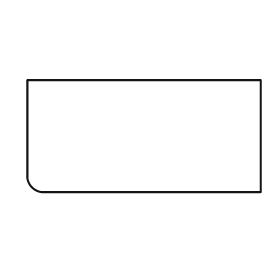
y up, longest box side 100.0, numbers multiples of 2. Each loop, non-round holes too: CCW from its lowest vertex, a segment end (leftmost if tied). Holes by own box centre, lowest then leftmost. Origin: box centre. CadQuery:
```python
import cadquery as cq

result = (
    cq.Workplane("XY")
    .moveTo(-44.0, -24.0)
    .lineTo(50.0, -24.0)
    .lineTo(50.0, 24.0)
    .lineTo(-50.0, 24.0)
    .lineTo(-50.0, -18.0)
    .threePointArc((-48.0, -22.0), (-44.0, -24.0))
    .close()
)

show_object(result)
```